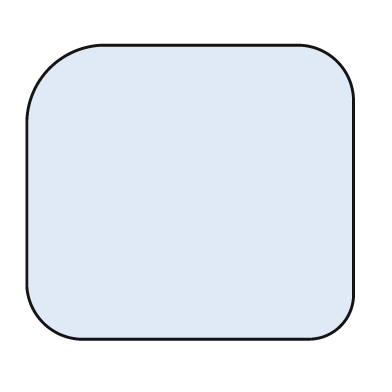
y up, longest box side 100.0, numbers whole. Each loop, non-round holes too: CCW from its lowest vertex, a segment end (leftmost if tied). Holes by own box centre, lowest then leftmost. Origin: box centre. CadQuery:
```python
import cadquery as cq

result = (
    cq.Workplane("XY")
    .moveTo(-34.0, -45.0)
    .lineTo(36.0, -45.0)
    .threePointArc((46.0, -41.0), (50.0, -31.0))
    .lineTo(50.0, 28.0)
    .threePointArc((45.0, 40.0), (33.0, 45.0))
    .lineTo(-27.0, 45.0)
    .threePointArc((-43.0, 38.0), (-50.0, 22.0))
    .lineTo(-50.0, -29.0)
    .threePointArc((-45.0, -40.0), (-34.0, -45.0))
    .close()
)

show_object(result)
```